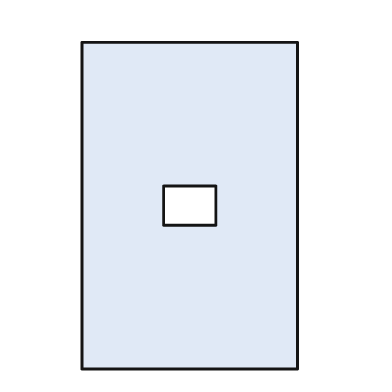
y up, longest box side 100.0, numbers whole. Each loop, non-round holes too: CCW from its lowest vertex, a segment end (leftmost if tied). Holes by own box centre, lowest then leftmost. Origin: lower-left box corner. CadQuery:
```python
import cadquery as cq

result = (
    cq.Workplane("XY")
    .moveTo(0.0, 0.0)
    .lineTo(66.0, 0.0)
    .lineTo(66.0, 100.0)
    .lineTo(0.0, 100.0)
    .close()
    .moveTo(25.0, 44.0)
    .lineTo(41.0, 44.0)
    .lineTo(41.0, 56.0)
    .lineTo(25.0, 56.0)
    .close()
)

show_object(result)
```